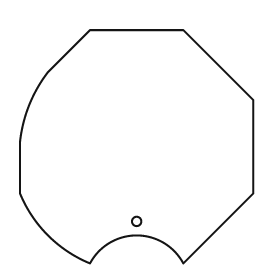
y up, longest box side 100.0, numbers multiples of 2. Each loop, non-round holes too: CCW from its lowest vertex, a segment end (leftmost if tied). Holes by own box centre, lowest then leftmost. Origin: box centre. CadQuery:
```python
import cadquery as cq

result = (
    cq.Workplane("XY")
    .moveTo(-20.0, -50.0)
    .threePointArc((0.0, -38.0), (20.0, -50.0))
    .lineTo(50.0, -20.0)
    .lineTo(50.0, 20.0)
    .lineTo(20.0, 50.0)
    .lineTo(-20.0, 50.0)
    .lineTo(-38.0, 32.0)
    .threePointArc((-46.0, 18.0), (-50.0, 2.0))
    .lineTo(-50.0, -20.0)
    .threePointArc((-38.0, -38.0), (-20.0, -50.0))
    .close()
    .moveTo(0.0, -32.0)
    .circle(2.0)
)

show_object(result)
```